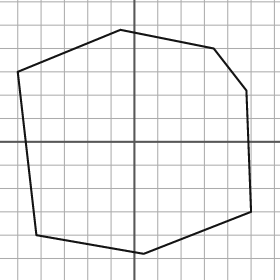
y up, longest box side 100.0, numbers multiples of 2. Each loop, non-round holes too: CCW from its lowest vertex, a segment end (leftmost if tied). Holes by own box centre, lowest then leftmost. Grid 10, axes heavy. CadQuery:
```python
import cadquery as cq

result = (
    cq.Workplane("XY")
    .moveTo(4.0, -48.0)
    .lineTo(50.0, -30.0)
    .lineTo(48.0, 22.0)
    .lineTo(34.0, 40.0)
    .lineTo(-6.0, 48.0)
    .lineTo(-50.0, 30.0)
    .lineTo(-42.0, -40.0)
    .close()
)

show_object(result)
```